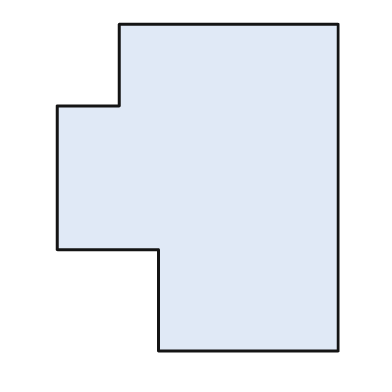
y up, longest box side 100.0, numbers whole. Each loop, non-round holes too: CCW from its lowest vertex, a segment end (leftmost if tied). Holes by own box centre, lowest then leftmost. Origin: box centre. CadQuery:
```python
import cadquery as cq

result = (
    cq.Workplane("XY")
    .moveTo(-12.0, -50.0)
    .lineTo(43.0, -50.0)
    .lineTo(43.0, 50.0)
    .lineTo(-24.0, 50.0)
    .lineTo(-24.0, 25.0)
    .lineTo(-43.0, 25.0)
    .lineTo(-43.0, -19.0)
    .lineTo(-12.0, -19.0)
    .close()
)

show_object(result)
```